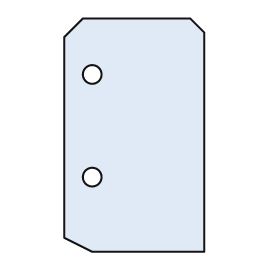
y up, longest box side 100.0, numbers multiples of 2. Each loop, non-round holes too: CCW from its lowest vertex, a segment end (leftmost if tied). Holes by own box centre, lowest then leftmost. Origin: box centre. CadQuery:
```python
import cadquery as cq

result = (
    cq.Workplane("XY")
    .moveTo(-18.0, -50.0)
    .lineTo(30.0, -50.0)
    .lineTo(30.0, 44.0)
    .lineTo(24.0, 50.0)
    .lineTo(-22.0, 50.0)
    .lineTo(-30.0, 42.0)
    .lineTo(-30.0, -44.0)
    .close()
    .moveTo(-18.0, -18.0)
    .circle(4.0)
    .moveTo(-18.0, 26.0)
    .circle(4.0)
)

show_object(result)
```